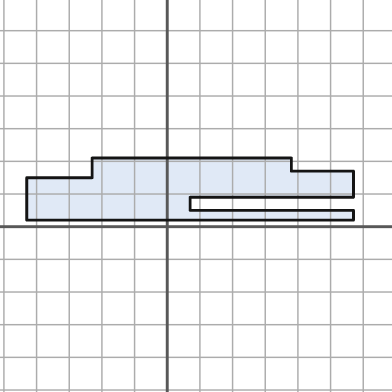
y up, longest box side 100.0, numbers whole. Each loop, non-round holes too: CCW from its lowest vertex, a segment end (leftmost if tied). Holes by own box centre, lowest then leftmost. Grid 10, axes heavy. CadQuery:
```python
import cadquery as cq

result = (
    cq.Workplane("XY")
    .moveTo(-43.0, 2.0)
    .lineTo(57.0, 2.0)
    .lineTo(57.0, 5.0)
    .lineTo(7.0, 5.0)
    .lineTo(7.0, 9.0)
    .lineTo(57.0, 9.0)
    .lineTo(57.0, 17.0)
    .lineTo(38.0, 17.0)
    .lineTo(38.0, 21.0)
    .lineTo(-23.0, 21.0)
    .lineTo(-23.0, 15.0)
    .lineTo(-43.0, 15.0)
    .close()
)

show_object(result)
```